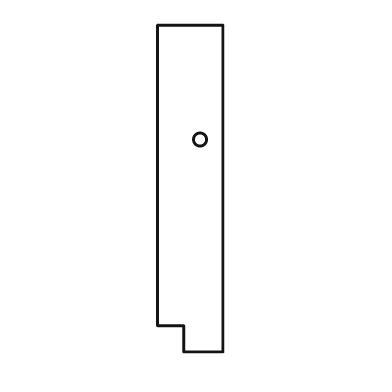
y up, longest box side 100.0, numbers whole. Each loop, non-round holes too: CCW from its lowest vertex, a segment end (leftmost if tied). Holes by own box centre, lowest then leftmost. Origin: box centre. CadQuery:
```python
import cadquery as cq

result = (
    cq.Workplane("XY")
    .moveTo(-2.0, -50.0)
    .lineTo(10.0, -50.0)
    .lineTo(10.0, 50.0)
    .lineTo(-10.0, 50.0)
    .lineTo(-10.0, -42.0)
    .lineTo(-2.0, -42.0)
    .close()
    .moveTo(3.0, 15.0)
    .circle(2.0)
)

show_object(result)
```